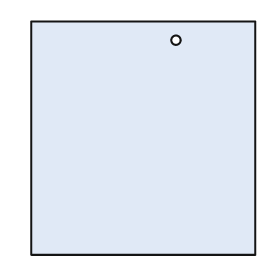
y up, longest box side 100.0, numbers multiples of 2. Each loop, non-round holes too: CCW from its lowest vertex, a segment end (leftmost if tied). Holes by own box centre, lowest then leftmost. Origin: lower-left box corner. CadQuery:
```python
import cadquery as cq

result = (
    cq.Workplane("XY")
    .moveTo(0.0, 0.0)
    .lineTo(96.0, 0.0)
    .lineTo(96.0, 100.0)
    .lineTo(0.0, 100.0)
    .close()
    .moveTo(62.0, 92.0)
    .circle(2.0)
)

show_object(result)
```